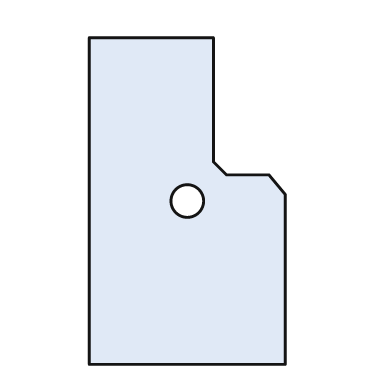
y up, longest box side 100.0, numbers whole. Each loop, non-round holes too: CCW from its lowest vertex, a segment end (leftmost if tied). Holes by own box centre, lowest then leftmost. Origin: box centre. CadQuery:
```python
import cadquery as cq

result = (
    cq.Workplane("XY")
    .moveTo(-30.0, -50.0)
    .lineTo(30.0, -50.0)
    .lineTo(30.0, 2.0)
    .lineTo(25.0, 8.0)
    .lineTo(12.0, 8.0)
    .lineTo(8.0, 12.0)
    .lineTo(8.0, 50.0)
    .lineTo(-30.0, 50.0)
    .close()
    .moveTo(0.0, 0.0)
    .circle(5.0)
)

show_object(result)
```